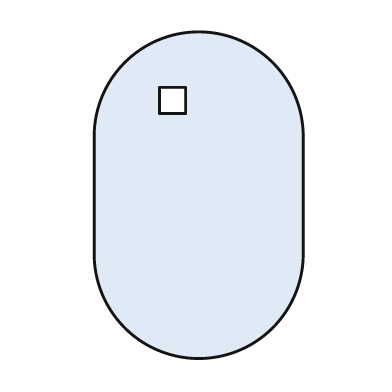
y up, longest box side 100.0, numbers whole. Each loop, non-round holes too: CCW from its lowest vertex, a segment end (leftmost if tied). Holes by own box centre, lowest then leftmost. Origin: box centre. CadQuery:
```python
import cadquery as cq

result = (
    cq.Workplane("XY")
    .moveTo(-32.0, -18.0)
    .threePointArc((0.0, -50.0), (32.0, -18.0))
    .lineTo(32.0, 18.0)
    .threePointArc((0.0, 50.0), (-32.0, 18.0))
    .close()
    .moveTo(-12.0, 25.0)
    .lineTo(-4.0, 25.0)
    .lineTo(-4.0, 33.0)
    .lineTo(-12.0, 33.0)
    .close()
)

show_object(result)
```